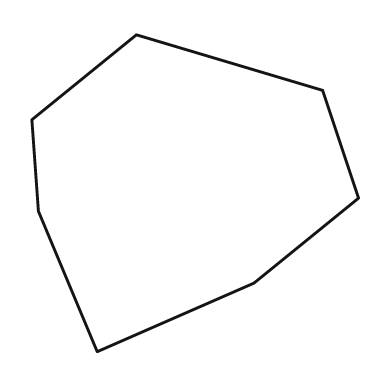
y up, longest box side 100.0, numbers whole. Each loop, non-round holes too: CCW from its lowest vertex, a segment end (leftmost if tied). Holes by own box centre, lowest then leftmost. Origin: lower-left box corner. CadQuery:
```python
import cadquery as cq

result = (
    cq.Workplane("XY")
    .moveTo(20.0, 0.0)
    .lineTo(68.0, 21.0)
    .lineTo(100.0, 47.0)
    .lineTo(89.0, 80.0)
    .lineTo(32.0, 97.0)
    .lineTo(0.0, 71.0)
    .lineTo(2.0, 43.0)
    .close()
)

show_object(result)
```